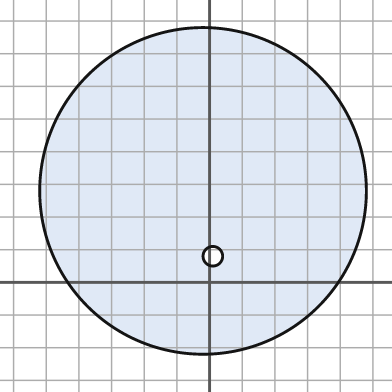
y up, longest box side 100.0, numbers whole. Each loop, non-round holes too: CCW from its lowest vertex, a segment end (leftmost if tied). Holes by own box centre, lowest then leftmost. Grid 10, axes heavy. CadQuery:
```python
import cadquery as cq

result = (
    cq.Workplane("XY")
    .moveTo(-2.0, 28.0)
    .circle(50.0)
    .moveTo(1.0, 8.0)
    .circle(3.0)
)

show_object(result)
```